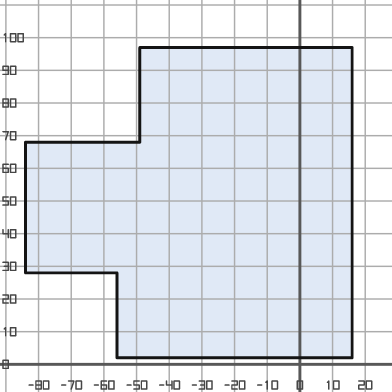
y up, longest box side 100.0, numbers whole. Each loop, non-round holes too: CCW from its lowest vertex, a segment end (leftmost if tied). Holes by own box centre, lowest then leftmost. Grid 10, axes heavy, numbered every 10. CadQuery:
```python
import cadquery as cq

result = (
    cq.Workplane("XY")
    .moveTo(-56.0, 2.0)
    .lineTo(16.0, 2.0)
    .lineTo(16.0, 97.0)
    .lineTo(-49.0, 97.0)
    .lineTo(-49.0, 68.0)
    .lineTo(-84.0, 68.0)
    .lineTo(-84.0, 28.0)
    .lineTo(-56.0, 28.0)
    .close()
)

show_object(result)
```